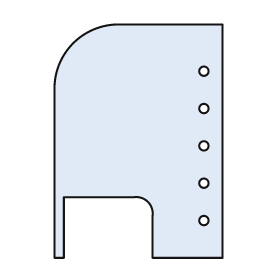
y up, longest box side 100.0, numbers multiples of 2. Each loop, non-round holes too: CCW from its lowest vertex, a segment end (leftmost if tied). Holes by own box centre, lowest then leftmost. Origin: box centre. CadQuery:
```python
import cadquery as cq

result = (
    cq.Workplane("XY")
    .moveTo(-36.0, -50.0)
    .lineTo(-32.0, -50.0)
    .lineTo(-32.0, -24.0)
    .lineTo(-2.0, -24.0)
    .threePointArc((4.0, -26.0), (6.0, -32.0))
    .lineTo(6.0, -50.0)
    .lineTo(36.0, -50.0)
    .lineTo(36.0, 50.0)
    .lineTo(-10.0, 50.0)
    .threePointArc((-28.0, 42.0), (-36.0, 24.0))
    .close()
    .moveTo(28.0, -34.0)
    .circle(2.0)
    .moveTo(28.0, -18.0)
    .circle(2.0)
    .moveTo(28.0, -2.0)
    .circle(2.0)
    .moveTo(28.0, 14.0)
    .circle(2.0)
    .moveTo(28.0, 30.0)
    .circle(2.0)
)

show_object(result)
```